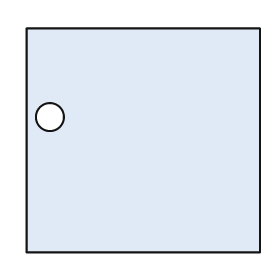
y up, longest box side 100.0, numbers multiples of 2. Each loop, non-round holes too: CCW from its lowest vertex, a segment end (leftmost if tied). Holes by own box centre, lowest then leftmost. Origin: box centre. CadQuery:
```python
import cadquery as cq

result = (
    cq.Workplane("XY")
    .moveTo(-50.0, -48.0)
    .lineTo(50.0, -48.0)
    .lineTo(50.0, 48.0)
    .lineTo(-50.0, 48.0)
    .close()
    .moveTo(-40.0, 10.0)
    .circle(6.0)
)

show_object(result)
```